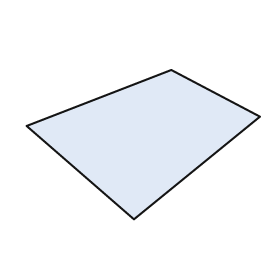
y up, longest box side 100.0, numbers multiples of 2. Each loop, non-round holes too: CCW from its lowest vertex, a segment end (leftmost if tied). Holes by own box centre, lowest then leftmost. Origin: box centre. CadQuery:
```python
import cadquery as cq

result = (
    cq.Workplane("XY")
    .moveTo(-4.0, -32.0)
    .lineTo(50.0, 12.0)
    .lineTo(12.0, 32.0)
    .lineTo(-50.0, 8.0)
    .close()
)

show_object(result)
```